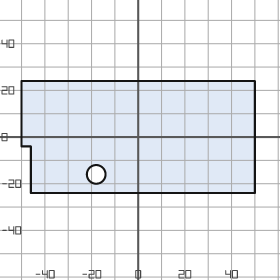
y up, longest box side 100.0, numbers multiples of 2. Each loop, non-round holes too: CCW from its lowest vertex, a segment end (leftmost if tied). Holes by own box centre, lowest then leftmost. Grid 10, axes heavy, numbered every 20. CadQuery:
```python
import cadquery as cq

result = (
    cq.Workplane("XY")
    .moveTo(-46.0, -24.0)
    .lineTo(50.0, -24.0)
    .lineTo(50.0, 24.0)
    .lineTo(-50.0, 24.0)
    .lineTo(-50.0, -4.0)
    .lineTo(-46.0, -4.0)
    .close()
    .moveTo(-18.0, -16.0)
    .circle(4.0)
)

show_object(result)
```